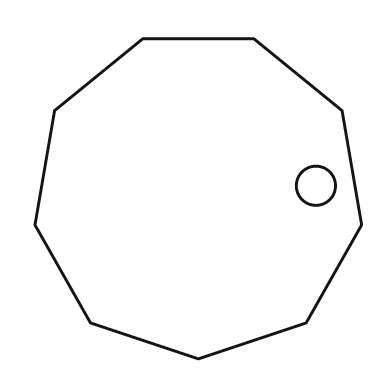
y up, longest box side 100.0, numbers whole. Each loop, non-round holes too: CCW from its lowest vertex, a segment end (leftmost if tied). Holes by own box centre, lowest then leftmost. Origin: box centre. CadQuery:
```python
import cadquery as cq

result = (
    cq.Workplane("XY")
    .moveTo(0.0, -49.0)
    .lineTo(33.0, -38.0)
    .lineTo(50.0, -8.0)
    .lineTo(44.0, 27.0)
    .lineTo(17.0, 49.0)
    .lineTo(-17.0, 49.0)
    .lineTo(-44.0, 27.0)
    .lineTo(-50.0, -8.0)
    .lineTo(-33.0, -38.0)
    .close()
    .moveTo(36.0, 4.0)
    .circle(6.0)
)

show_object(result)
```